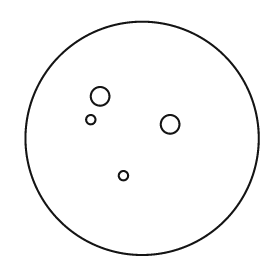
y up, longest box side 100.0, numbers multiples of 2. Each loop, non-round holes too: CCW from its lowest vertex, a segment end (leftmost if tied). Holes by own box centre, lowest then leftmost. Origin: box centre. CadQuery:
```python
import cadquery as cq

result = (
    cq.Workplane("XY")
    .moveTo(0.0, 0.0)
    .circle(50.0)
    .moveTo(-8.0, -16.0)
    .circle(2.0)
    .moveTo(12.0, 6.0)
    .circle(4.0)
    .moveTo(-22.0, 8.0)
    .circle(2.0)
    .moveTo(-18.0, 18.0)
    .circle(4.0)
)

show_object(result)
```